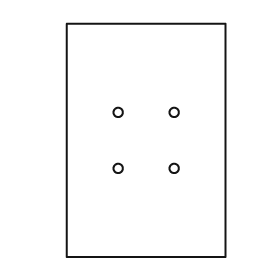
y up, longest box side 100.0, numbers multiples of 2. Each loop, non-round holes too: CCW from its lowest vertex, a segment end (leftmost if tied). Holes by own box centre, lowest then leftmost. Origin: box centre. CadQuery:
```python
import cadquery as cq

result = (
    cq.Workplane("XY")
    .moveTo(-34.0, -50.0)
    .lineTo(34.0, -50.0)
    .lineTo(34.0, 50.0)
    .lineTo(-34.0, 50.0)
    .close()
    .moveTo(-12.0, -12.0)
    .circle(2.0)
    .moveTo(12.0, -12.0)
    .circle(2.0)
    .moveTo(-12.0, 12.0)
    .circle(2.0)
    .moveTo(12.0, 12.0)
    .circle(2.0)
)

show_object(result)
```